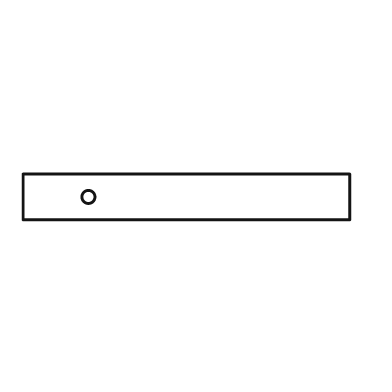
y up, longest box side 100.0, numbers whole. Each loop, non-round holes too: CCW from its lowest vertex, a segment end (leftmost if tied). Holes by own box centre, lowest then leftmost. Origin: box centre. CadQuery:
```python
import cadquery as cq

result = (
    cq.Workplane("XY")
    .moveTo(-50.0, -7.0)
    .lineTo(50.0, -7.0)
    .lineTo(50.0, 7.0)
    .lineTo(-50.0, 7.0)
    .close()
    .moveTo(-30.0, 0.0)
    .circle(2.0)
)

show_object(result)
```